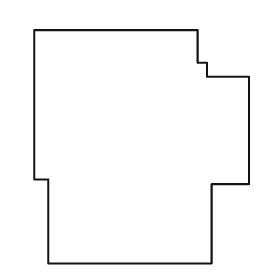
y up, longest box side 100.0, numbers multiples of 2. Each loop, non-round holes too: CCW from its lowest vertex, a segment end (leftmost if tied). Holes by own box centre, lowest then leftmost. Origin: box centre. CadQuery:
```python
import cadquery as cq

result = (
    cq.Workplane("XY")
    .moveTo(-40.0, -50.0)
    .lineTo(30.0, -50.0)
    .lineTo(30.0, -16.0)
    .lineTo(46.0, -16.0)
    .lineTo(46.0, 30.0)
    .lineTo(28.0, 30.0)
    .lineTo(28.0, 36.0)
    .lineTo(24.0, 36.0)
    .lineTo(24.0, 50.0)
    .lineTo(-46.0, 50.0)
    .lineTo(-46.0, -14.0)
    .lineTo(-40.0, -14.0)
    .close()
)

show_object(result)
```